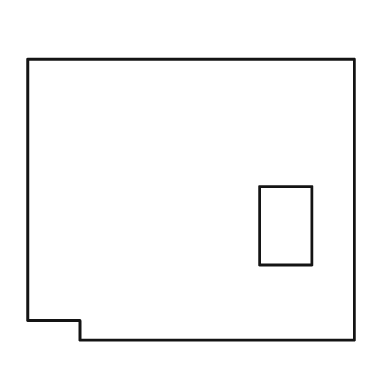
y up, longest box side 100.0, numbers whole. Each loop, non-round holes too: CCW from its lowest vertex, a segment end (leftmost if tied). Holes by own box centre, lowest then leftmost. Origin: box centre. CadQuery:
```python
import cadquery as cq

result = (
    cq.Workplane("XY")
    .moveTo(-34.0, -43.0)
    .lineTo(50.0, -43.0)
    .lineTo(50.0, 43.0)
    .lineTo(-50.0, 43.0)
    .lineTo(-50.0, -37.0)
    .lineTo(-34.0, -37.0)
    .close()
    .moveTo(21.0, -20.0)
    .lineTo(37.0, -20.0)
    .lineTo(37.0, 4.0)
    .lineTo(21.0, 4.0)
    .close()
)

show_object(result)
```